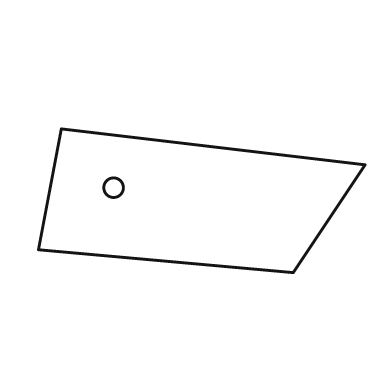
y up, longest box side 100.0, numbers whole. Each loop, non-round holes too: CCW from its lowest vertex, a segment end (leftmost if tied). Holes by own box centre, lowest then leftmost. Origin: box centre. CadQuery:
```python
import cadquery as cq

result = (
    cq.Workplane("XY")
    .moveTo(28.0, -22.0)
    .lineTo(50.0, 11.0)
    .lineTo(-43.0, 22.0)
    .lineTo(-50.0, -15.0)
    .close()
    .moveTo(-27.0, 4.0)
    .circle(3.0)
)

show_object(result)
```